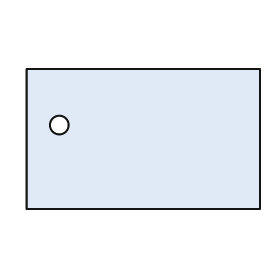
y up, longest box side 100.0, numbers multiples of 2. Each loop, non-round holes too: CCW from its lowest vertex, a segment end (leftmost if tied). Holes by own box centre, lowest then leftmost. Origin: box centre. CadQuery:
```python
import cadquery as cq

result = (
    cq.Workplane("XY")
    .moveTo(-50.0, -30.0)
    .lineTo(50.0, -30.0)
    .lineTo(50.0, 30.0)
    .lineTo(-50.0, 30.0)
    .close()
    .moveTo(-36.0, 6.0)
    .circle(4.0)
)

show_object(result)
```